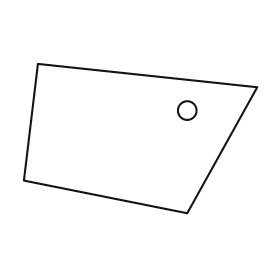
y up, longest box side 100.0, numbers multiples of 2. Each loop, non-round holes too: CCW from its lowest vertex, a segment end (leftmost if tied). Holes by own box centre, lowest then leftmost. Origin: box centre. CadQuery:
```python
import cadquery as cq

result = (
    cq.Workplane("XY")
    .moveTo(20.0, -32.0)
    .lineTo(50.0, 22.0)
    .lineTo(-44.0, 32.0)
    .lineTo(-50.0, -18.0)
    .close()
    .moveTo(20.0, 12.0)
    .circle(4.0)
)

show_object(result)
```